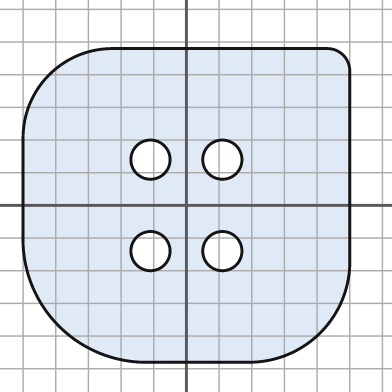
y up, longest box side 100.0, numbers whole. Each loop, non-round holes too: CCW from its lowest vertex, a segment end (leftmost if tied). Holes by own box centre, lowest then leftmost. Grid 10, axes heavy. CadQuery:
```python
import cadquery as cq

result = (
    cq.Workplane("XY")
    .moveTo(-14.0, -48.0)
    .lineTo(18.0, -48.0)
    .threePointArc((41.0, -39.0), (50.0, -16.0))
    .lineTo(50.0, 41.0)
    .threePointArc((48.0, 46.0), (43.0, 48.0))
    .lineTo(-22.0, 48.0)
    .threePointArc((-42.0, 40.0), (-50.0, 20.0))
    .lineTo(-50.0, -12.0)
    .threePointArc((-39.0, -37.0), (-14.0, -48.0))
    .close()
    .moveTo(-11.0, -14.0)
    .circle(6.0)
    .moveTo(11.0, -14.0)
    .circle(6.0)
    .moveTo(-11.0, 14.0)
    .circle(6.0)
    .moveTo(11.0, 14.0)
    .circle(6.0)
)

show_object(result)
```